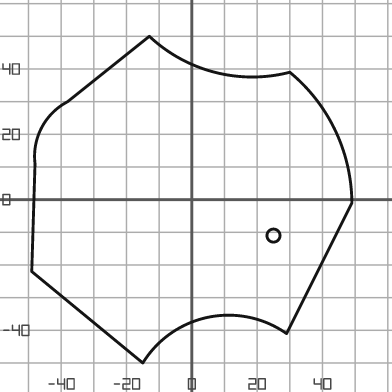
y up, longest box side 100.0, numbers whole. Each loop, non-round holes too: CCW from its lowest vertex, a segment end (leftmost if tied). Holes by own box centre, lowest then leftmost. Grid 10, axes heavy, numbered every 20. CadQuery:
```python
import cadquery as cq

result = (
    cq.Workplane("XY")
    .moveTo(-15.0, -50.0)
    .threePointArc((5.0, -36.0), (29.0, -41.0))
    .lineTo(49.0, -1.0)
    .threePointArc((44.0, 21.0), (30.0, 39.0))
    .threePointArc((7.0, 39.0), (-13.0, 50.0))
    .lineTo(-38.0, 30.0)
    .threePointArc((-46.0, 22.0), (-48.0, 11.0))
    .lineTo(-49.0, -22.0)
    .close()
    .moveTo(25.0, -11.0)
    .circle(2.0)
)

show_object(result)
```